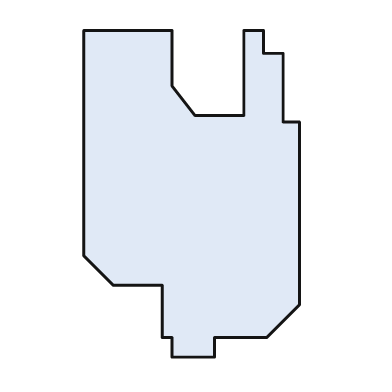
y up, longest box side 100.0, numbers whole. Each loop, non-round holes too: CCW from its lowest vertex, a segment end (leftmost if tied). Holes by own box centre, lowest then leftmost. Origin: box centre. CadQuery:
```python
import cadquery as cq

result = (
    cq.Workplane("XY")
    .moveTo(-6.0, -50.0)
    .lineTo(7.0, -50.0)
    .lineTo(7.0, -44.0)
    .lineTo(23.0, -44.0)
    .lineTo(33.0, -34.0)
    .lineTo(33.0, 22.0)
    .lineTo(28.0, 22.0)
    .lineTo(28.0, 43.0)
    .lineTo(22.0, 43.0)
    .lineTo(22.0, 50.0)
    .lineTo(16.0, 50.0)
    .lineTo(16.0, 24.0)
    .lineTo(1.0, 24.0)
    .lineTo(-6.0, 33.0)
    .lineTo(-6.0, 50.0)
    .lineTo(-33.0, 50.0)
    .lineTo(-33.0, -19.0)
    .lineTo(-24.0, -28.0)
    .lineTo(-9.0, -28.0)
    .lineTo(-9.0, -44.0)
    .lineTo(-6.0, -44.0)
    .close()
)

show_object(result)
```